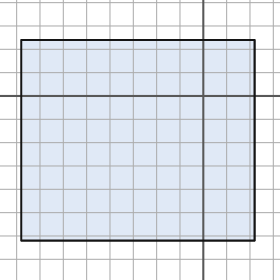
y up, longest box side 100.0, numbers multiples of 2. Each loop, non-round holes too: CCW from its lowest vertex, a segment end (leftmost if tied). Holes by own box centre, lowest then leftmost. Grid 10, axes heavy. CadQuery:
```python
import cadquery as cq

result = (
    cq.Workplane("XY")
    .moveTo(-78.0, -62.0)
    .lineTo(22.0, -62.0)
    .lineTo(22.0, 24.0)
    .lineTo(-78.0, 24.0)
    .close()
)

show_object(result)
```